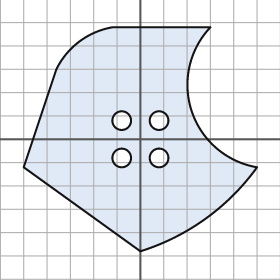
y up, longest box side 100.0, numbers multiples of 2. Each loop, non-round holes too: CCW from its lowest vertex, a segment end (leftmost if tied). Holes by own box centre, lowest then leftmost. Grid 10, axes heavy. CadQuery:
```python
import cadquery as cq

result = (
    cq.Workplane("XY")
    .moveTo(0.0, -48.0)
    .threePointArc((28.0, -34.0), (50.0, -12.0))
    .threePointArc((22.0, 12.0), (30.0, 48.0))
    .lineTo(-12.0, 48.0)
    .threePointArc((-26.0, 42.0), (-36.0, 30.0))
    .lineTo(-50.0, -12.0)
    .close()
    .moveTo(-8.0, -8.0)
    .circle(4.0)
    .moveTo(8.0, -8.0)
    .circle(4.0)
    .moveTo(-8.0, 8.0)
    .circle(4.0)
    .moveTo(8.0, 8.0)
    .circle(4.0)
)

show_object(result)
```